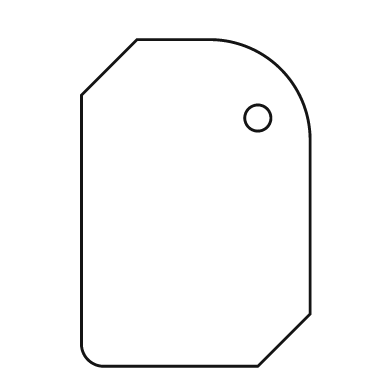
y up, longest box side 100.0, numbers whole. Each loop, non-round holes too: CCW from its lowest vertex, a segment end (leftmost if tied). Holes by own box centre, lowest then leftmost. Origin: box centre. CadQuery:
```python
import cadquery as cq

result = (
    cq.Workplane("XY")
    .moveTo(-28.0, -50.0)
    .lineTo(19.0, -50.0)
    .lineTo(35.0, -34.0)
    .lineTo(35.0, 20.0)
    .threePointArc((26.0, 41.0), (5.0, 50.0))
    .lineTo(-18.0, 50.0)
    .lineTo(-35.0, 33.0)
    .lineTo(-35.0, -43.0)
    .threePointArc((-33.0, -48.0), (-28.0, -50.0))
    .close()
    .moveTo(19.0, 26.0)
    .circle(4.0)
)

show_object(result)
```